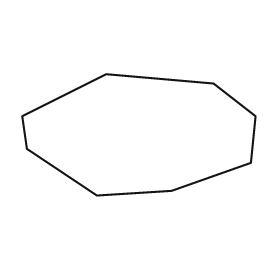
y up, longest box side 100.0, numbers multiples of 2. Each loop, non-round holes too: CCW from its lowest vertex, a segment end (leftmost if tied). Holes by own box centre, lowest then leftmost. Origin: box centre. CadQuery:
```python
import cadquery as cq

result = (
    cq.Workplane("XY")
    .moveTo(-18.0, -26.0)
    .lineTo(14.0, -24.0)
    .lineTo(48.0, -12.0)
    .lineTo(50.0, 8.0)
    .lineTo(32.0, 22.0)
    .lineTo(-14.0, 26.0)
    .lineTo(-50.0, 8.0)
    .lineTo(-48.0, -6.0)
    .close()
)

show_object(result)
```